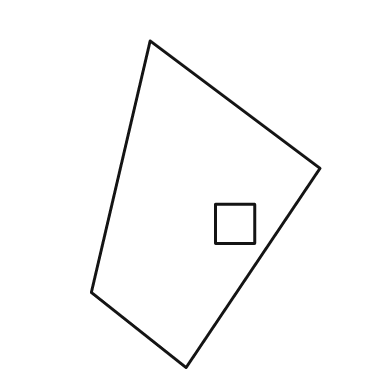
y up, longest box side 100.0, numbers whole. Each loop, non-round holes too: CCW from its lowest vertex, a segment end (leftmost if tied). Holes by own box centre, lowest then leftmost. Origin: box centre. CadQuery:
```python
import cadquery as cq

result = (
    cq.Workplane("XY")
    .moveTo(-6.0, -50.0)
    .lineTo(35.0, 11.0)
    .lineTo(-17.0, 50.0)
    .lineTo(-35.0, -27.0)
    .close()
    .moveTo(3.0, -12.0)
    .lineTo(15.0, -12.0)
    .lineTo(15.0, 0.0)
    .lineTo(3.0, 0.0)
    .close()
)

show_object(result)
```